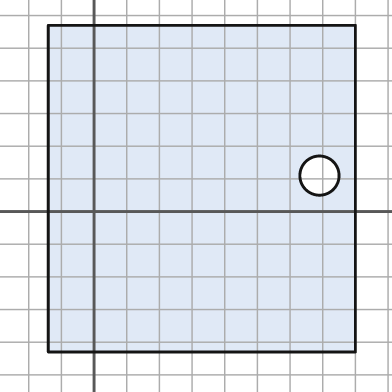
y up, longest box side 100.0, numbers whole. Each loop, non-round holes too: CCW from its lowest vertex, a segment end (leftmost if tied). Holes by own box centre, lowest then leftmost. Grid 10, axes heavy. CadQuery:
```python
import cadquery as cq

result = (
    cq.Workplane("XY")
    .moveTo(-14.0, -43.0)
    .lineTo(80.0, -43.0)
    .lineTo(80.0, 57.0)
    .lineTo(-14.0, 57.0)
    .close()
    .moveTo(69.0, 11.0)
    .circle(6.0)
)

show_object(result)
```